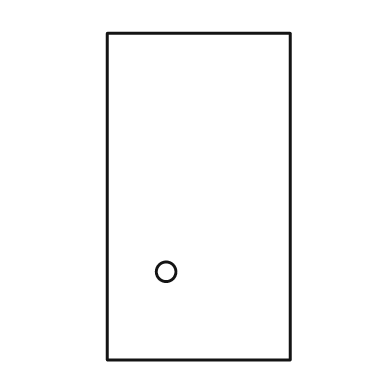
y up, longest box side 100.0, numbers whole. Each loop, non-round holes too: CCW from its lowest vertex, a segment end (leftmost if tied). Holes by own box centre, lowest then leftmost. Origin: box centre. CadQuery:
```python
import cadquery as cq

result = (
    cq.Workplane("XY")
    .moveTo(-28.0, -50.0)
    .lineTo(28.0, -50.0)
    .lineTo(28.0, 50.0)
    .lineTo(-28.0, 50.0)
    .close()
    .moveTo(-10.0, -23.0)
    .circle(3.0)
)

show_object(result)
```